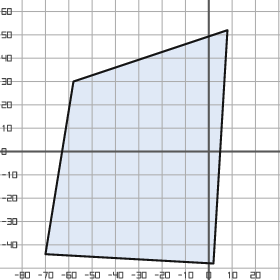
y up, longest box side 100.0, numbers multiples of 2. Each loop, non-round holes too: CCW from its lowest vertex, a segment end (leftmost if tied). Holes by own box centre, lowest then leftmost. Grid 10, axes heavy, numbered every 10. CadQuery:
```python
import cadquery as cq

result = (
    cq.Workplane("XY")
    .moveTo(2.0, -48.0)
    .lineTo(8.0, 52.0)
    .lineTo(-58.0, 30.0)
    .lineTo(-70.0, -44.0)
    .close()
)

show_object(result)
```